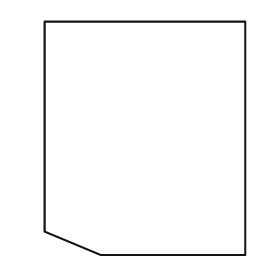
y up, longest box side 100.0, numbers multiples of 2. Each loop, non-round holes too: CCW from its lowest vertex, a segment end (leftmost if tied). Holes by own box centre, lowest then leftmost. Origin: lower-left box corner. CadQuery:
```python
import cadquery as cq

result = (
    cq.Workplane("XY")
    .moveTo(24.0, 0.0)
    .lineTo(86.0, 0.0)
    .lineTo(86.0, 100.0)
    .lineTo(0.0, 100.0)
    .lineTo(0.0, 10.0)
    .close()
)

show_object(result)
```